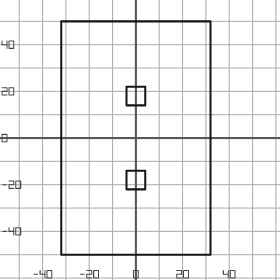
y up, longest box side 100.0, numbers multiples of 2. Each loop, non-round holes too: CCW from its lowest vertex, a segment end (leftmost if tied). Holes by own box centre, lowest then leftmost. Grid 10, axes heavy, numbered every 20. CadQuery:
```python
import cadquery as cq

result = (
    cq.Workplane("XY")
    .moveTo(-32.0, -50.0)
    .lineTo(32.0, -50.0)
    .lineTo(32.0, 50.0)
    .lineTo(-32.0, 50.0)
    .close()
    .moveTo(-4.0, -22.0)
    .lineTo(4.0, -22.0)
    .lineTo(4.0, -14.0)
    .lineTo(-4.0, -14.0)
    .close()
    .moveTo(-4.0, 14.0)
    .lineTo(4.0, 14.0)
    .lineTo(4.0, 22.0)
    .lineTo(-4.0, 22.0)
    .close()
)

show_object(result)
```